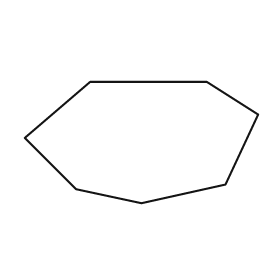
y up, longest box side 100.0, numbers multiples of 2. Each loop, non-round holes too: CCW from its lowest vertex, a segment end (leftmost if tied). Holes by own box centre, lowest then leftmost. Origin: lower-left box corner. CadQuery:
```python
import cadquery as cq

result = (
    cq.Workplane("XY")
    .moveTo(50.0, 0.0)
    .lineTo(86.0, 8.0)
    .lineTo(100.0, 38.0)
    .lineTo(78.0, 52.0)
    .lineTo(28.0, 52.0)
    .lineTo(0.0, 28.0)
    .lineTo(22.0, 6.0)
    .close()
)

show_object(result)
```